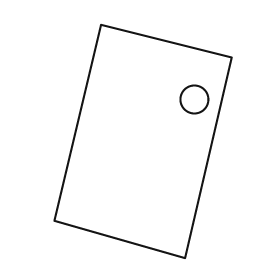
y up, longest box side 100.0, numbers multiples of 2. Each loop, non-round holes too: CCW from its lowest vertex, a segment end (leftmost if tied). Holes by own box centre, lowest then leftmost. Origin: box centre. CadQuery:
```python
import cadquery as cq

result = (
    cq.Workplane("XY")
    .moveTo(18.0, -50.0)
    .lineTo(38.0, 36.0)
    .lineTo(-18.0, 50.0)
    .lineTo(-38.0, -34.0)
    .close()
    .moveTo(22.0, 18.0)
    .circle(6.0)
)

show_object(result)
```